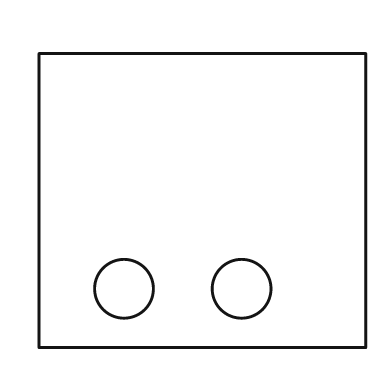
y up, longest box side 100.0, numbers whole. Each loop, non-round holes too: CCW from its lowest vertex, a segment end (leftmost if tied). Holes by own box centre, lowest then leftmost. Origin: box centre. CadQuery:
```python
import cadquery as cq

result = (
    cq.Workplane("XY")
    .moveTo(-50.0, -45.0)
    .lineTo(50.0, -45.0)
    .lineTo(50.0, 45.0)
    .lineTo(-50.0, 45.0)
    .close()
    .moveTo(-24.0, -27.0)
    .circle(9.0)
    .moveTo(12.0, -27.0)
    .circle(9.0)
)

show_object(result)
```